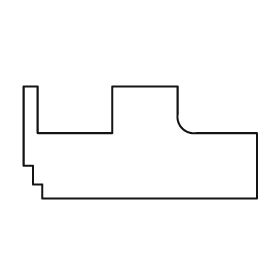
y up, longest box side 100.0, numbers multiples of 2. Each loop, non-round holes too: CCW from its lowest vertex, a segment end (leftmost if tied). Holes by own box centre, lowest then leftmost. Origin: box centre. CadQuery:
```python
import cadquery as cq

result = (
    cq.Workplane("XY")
    .moveTo(-42.0, -24.0)
    .lineTo(50.0, -24.0)
    .lineTo(50.0, 4.0)
    .lineTo(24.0, 4.0)
    .threePointArc((18.0, 6.0), (16.0, 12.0))
    .lineTo(16.0, 24.0)
    .lineTo(-12.0, 24.0)
    .lineTo(-12.0, 4.0)
    .lineTo(-44.0, 4.0)
    .lineTo(-44.0, 24.0)
    .lineTo(-50.0, 24.0)
    .lineTo(-50.0, -10.0)
    .lineTo(-46.0, -10.0)
    .lineTo(-46.0, -18.0)
    .lineTo(-42.0, -18.0)
    .close()
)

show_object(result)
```